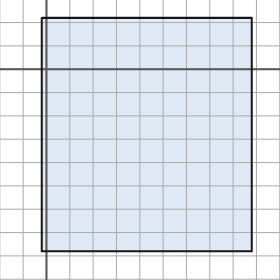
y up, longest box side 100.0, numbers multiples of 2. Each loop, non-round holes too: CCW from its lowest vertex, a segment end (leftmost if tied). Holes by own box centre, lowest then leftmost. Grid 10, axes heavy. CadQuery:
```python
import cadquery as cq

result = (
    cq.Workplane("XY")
    .moveTo(-2.0, -78.0)
    .lineTo(88.0, -78.0)
    .lineTo(88.0, 22.0)
    .lineTo(-2.0, 22.0)
    .close()
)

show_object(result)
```